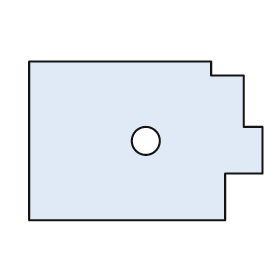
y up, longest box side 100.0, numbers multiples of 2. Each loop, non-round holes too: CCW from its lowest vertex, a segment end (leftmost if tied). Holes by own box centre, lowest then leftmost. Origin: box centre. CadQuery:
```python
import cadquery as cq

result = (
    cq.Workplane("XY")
    .moveTo(-50.0, -34.0)
    .lineTo(34.0, -34.0)
    .lineTo(34.0, -14.0)
    .lineTo(50.0, -14.0)
    .lineTo(50.0, 6.0)
    .lineTo(42.0, 6.0)
    .lineTo(42.0, 28.0)
    .lineTo(28.0, 28.0)
    .lineTo(28.0, 34.0)
    .lineTo(-50.0, 34.0)
    .close()
    .moveTo(0.0, 0.0)
    .circle(6.0)
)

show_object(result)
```